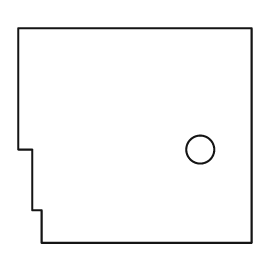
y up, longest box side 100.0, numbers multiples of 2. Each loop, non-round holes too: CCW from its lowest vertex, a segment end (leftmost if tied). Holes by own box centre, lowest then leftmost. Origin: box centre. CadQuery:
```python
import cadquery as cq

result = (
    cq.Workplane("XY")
    .moveTo(-40.0, -46.0)
    .lineTo(50.0, -46.0)
    .lineTo(50.0, 46.0)
    .lineTo(-50.0, 46.0)
    .lineTo(-50.0, -6.0)
    .lineTo(-44.0, -6.0)
    .lineTo(-44.0, -32.0)
    .lineTo(-40.0, -32.0)
    .close()
    .moveTo(28.0, -6.0)
    .circle(6.0)
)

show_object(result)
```